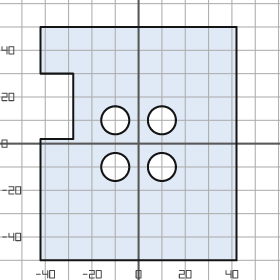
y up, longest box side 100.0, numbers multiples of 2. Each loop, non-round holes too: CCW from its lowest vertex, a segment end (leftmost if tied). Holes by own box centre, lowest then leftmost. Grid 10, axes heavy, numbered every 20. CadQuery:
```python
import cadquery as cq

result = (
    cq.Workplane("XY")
    .moveTo(-42.0, -50.0)
    .lineTo(42.0, -50.0)
    .lineTo(42.0, 50.0)
    .lineTo(-42.0, 50.0)
    .lineTo(-42.0, 30.0)
    .lineTo(-28.0, 30.0)
    .lineTo(-28.0, 2.0)
    .lineTo(-42.0, 2.0)
    .close()
    .moveTo(-10.0, -10.0)
    .circle(6.0)
    .moveTo(10.0, -10.0)
    .circle(6.0)
    .moveTo(-10.0, 10.0)
    .circle(6.0)
    .moveTo(10.0, 10.0)
    .circle(6.0)
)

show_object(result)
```